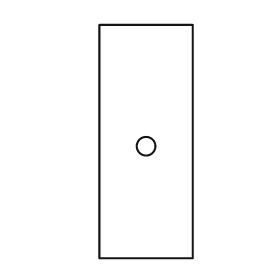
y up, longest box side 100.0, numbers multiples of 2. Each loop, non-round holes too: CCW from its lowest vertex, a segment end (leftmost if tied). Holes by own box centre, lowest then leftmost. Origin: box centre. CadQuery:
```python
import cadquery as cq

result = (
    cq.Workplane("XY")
    .moveTo(-20.0, -50.0)
    .lineTo(20.0, -50.0)
    .lineTo(20.0, 50.0)
    .lineTo(-20.0, 50.0)
    .close()
    .moveTo(0.0, -2.0)
    .circle(4.0)
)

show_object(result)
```